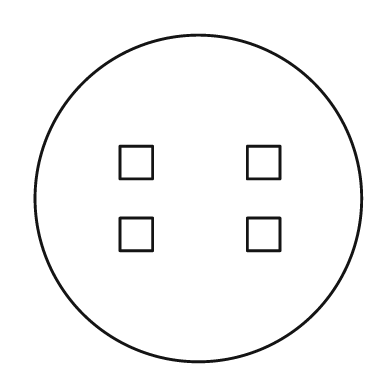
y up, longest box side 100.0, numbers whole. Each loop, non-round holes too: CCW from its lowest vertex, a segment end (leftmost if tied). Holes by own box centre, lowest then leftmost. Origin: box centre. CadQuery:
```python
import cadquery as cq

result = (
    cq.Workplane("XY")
    .moveTo(0.0, 0.0)
    .circle(50.0)
    .moveTo(-24.0, -16.0)
    .lineTo(-14.0, -16.0)
    .lineTo(-14.0, -6.0)
    .lineTo(-24.0, -6.0)
    .close()
    .moveTo(15.0, -16.0)
    .lineTo(25.0, -16.0)
    .lineTo(25.0, -6.0)
    .lineTo(15.0, -6.0)
    .close()
    .moveTo(-24.0, 6.0)
    .lineTo(-14.0, 6.0)
    .lineTo(-14.0, 16.0)
    .lineTo(-24.0, 16.0)
    .close()
    .moveTo(15.0, 6.0)
    .lineTo(25.0, 6.0)
    .lineTo(25.0, 16.0)
    .lineTo(15.0, 16.0)
    .close()
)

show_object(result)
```